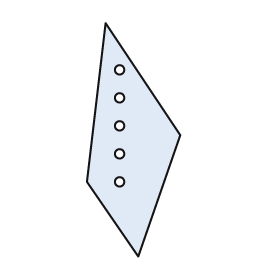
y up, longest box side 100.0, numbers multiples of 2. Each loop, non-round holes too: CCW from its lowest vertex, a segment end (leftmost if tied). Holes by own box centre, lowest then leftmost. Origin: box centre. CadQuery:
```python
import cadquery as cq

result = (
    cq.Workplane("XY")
    .moveTo(2.0, -50.0)
    .lineTo(20.0, 2.0)
    .lineTo(-12.0, 50.0)
    .lineTo(-20.0, -18.0)
    .close()
    .moveTo(-6.0, -18.0)
    .circle(2.0)
    .moveTo(-6.0, -6.0)
    .circle(2.0)
    .moveTo(-6.0, 6.0)
    .circle(2.0)
    .moveTo(-6.0, 18.0)
    .circle(2.0)
    .moveTo(-6.0, 30.0)
    .circle(2.0)
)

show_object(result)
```